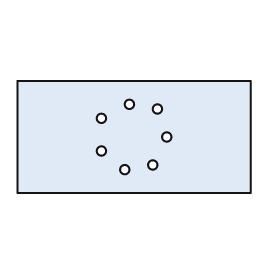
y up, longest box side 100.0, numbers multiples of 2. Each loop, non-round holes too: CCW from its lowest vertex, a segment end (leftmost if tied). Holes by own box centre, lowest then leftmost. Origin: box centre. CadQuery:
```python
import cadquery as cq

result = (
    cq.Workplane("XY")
    .moveTo(-50.0, -24.0)
    .lineTo(50.0, -24.0)
    .lineTo(50.0, 24.0)
    .lineTo(-50.0, 24.0)
    .close()
    .moveTo(-4.0, -14.0)
    .circle(2.0)
    .moveTo(8.0, -12.0)
    .circle(2.0)
    .moveTo(-14.0, -6.0)
    .circle(2.0)
    .moveTo(14.0, 0.0)
    .circle(2.0)
    .moveTo(-14.0, 8.0)
    .circle(2.0)
    .moveTo(10.0, 12.0)
    .circle(2.0)
    .moveTo(-2.0, 14.0)
    .circle(2.0)
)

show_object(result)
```